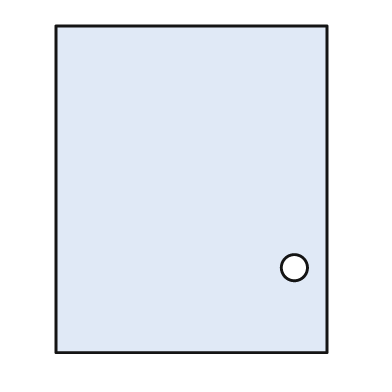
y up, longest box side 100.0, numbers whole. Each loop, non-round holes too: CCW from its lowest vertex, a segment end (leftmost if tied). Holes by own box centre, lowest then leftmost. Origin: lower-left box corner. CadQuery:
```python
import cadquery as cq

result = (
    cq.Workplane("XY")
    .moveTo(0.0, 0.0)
    .lineTo(83.0, 0.0)
    .lineTo(83.0, 100.0)
    .lineTo(0.0, 100.0)
    .close()
    .moveTo(73.0, 26.0)
    .circle(4.0)
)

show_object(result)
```